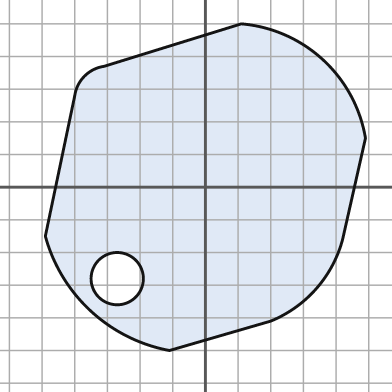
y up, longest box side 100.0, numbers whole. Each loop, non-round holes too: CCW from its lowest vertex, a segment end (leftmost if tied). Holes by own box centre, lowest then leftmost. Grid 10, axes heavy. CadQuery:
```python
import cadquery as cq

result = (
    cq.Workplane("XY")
    .moveTo(-11.0, -50.0)
    .lineTo(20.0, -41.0)
    .threePointArc((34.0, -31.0), (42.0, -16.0))
    .lineTo(49.0, 15.0)
    .threePointArc((36.0, 39.0), (11.0, 50.0))
    .lineTo(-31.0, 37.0)
    .threePointArc((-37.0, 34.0), (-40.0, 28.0))
    .lineTo(-49.0, -15.0)
    .threePointArc((-35.0, -38.0), (-11.0, -50.0))
    .close()
    .moveTo(-27.0, -28.0)
    .circle(8.0)
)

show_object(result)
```